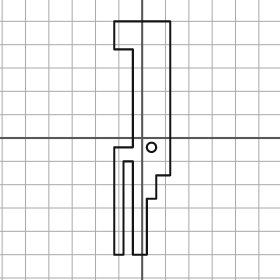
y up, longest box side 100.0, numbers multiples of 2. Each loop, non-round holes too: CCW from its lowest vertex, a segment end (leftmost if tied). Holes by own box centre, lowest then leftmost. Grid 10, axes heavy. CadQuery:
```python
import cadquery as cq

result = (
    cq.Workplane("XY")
    .moveTo(-12.0, -50.0)
    .lineTo(-8.0, -50.0)
    .lineTo(-8.0, -10.0)
    .lineTo(-4.0, -10.0)
    .lineTo(-4.0, -50.0)
    .lineTo(2.0, -50.0)
    .lineTo(2.0, -26.0)
    .lineTo(6.0, -26.0)
    .lineTo(6.0, -16.0)
    .lineTo(12.0, -16.0)
    .lineTo(12.0, 50.0)
    .lineTo(-12.0, 50.0)
    .lineTo(-12.0, 38.0)
    .lineTo(-4.0, 38.0)
    .lineTo(-4.0, -4.0)
    .lineTo(-12.0, -4.0)
    .close()
    .moveTo(4.0, -4.0)
    .circle(2.0)
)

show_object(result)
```